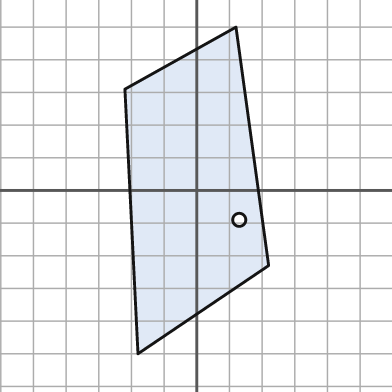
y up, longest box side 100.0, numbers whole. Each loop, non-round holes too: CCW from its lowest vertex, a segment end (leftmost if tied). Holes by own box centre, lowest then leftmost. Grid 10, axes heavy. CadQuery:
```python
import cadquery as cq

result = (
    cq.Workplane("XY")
    .moveTo(-18.0, -50.0)
    .lineTo(22.0, -23.0)
    .lineTo(12.0, 50.0)
    .lineTo(-22.0, 31.0)
    .close()
    .moveTo(13.0, -9.0)
    .circle(2.0)
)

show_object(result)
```